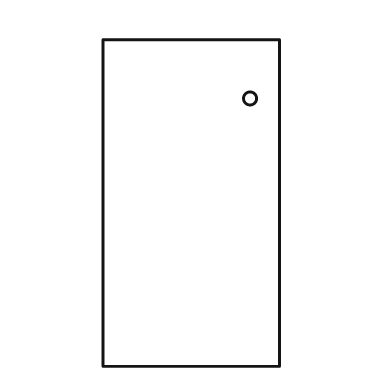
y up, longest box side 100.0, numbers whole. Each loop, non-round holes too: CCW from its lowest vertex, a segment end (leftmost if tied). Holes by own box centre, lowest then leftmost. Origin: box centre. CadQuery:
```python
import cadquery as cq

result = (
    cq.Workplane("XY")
    .moveTo(-27.0, -50.0)
    .lineTo(27.0, -50.0)
    .lineTo(27.0, 50.0)
    .lineTo(-27.0, 50.0)
    .close()
    .moveTo(18.0, 32.0)
    .circle(2.0)
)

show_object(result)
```